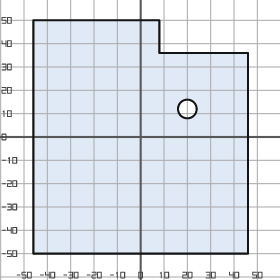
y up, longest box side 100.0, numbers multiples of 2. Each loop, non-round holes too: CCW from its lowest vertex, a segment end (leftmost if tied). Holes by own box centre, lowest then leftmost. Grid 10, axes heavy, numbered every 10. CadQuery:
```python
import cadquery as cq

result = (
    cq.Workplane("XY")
    .moveTo(-46.0, -50.0)
    .lineTo(46.0, -50.0)
    .lineTo(46.0, 36.0)
    .lineTo(8.0, 36.0)
    .lineTo(8.0, 50.0)
    .lineTo(-46.0, 50.0)
    .close()
    .moveTo(20.0, 12.0)
    .circle(4.0)
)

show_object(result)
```